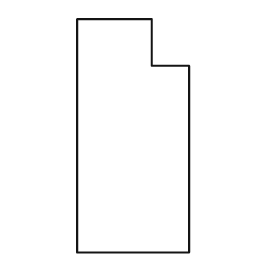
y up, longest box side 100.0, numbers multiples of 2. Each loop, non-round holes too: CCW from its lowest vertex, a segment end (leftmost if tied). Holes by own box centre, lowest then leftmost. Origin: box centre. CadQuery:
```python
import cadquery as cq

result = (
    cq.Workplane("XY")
    .moveTo(-24.0, -50.0)
    .lineTo(24.0, -50.0)
    .lineTo(24.0, 30.0)
    .lineTo(8.0, 30.0)
    .lineTo(8.0, 50.0)
    .lineTo(-24.0, 50.0)
    .close()
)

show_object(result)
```